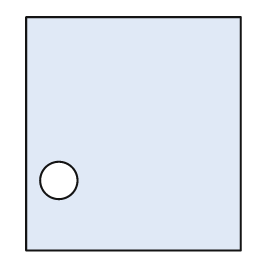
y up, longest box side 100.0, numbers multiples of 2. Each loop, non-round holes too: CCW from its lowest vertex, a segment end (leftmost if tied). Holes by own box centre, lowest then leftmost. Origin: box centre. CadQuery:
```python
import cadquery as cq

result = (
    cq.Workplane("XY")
    .moveTo(-46.0, -50.0)
    .lineTo(46.0, -50.0)
    .lineTo(46.0, 50.0)
    .lineTo(-46.0, 50.0)
    .close()
    .moveTo(-32.0, -20.0)
    .circle(8.0)
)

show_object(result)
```